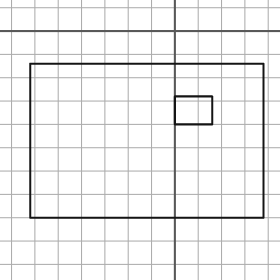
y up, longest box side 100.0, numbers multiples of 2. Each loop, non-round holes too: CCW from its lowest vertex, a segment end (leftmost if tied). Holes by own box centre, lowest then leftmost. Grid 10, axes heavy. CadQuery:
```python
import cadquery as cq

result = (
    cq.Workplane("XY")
    .moveTo(-62.0, -80.0)
    .lineTo(38.0, -80.0)
    .lineTo(38.0, -14.0)
    .lineTo(-62.0, -14.0)
    .close()
    .moveTo(0.0, -40.0)
    .lineTo(16.0, -40.0)
    .lineTo(16.0, -28.0)
    .lineTo(0.0, -28.0)
    .close()
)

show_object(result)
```